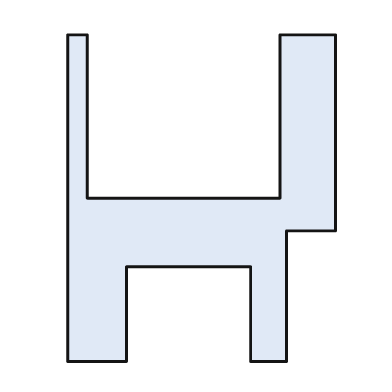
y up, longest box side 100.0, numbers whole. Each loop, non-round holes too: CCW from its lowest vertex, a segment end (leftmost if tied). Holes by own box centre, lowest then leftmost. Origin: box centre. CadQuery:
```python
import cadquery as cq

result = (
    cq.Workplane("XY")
    .moveTo(-41.0, -50.0)
    .lineTo(-23.0, -50.0)
    .lineTo(-23.0, -21.0)
    .lineTo(15.0, -21.0)
    .lineTo(15.0, -50.0)
    .lineTo(26.0, -50.0)
    .lineTo(26.0, -10.0)
    .lineTo(41.0, -10.0)
    .lineTo(41.0, 50.0)
    .lineTo(24.0, 50.0)
    .lineTo(24.0, 0.0)
    .lineTo(-35.0, 0.0)
    .lineTo(-35.0, 50.0)
    .lineTo(-41.0, 50.0)
    .close()
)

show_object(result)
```